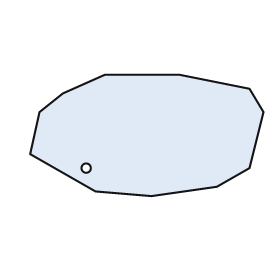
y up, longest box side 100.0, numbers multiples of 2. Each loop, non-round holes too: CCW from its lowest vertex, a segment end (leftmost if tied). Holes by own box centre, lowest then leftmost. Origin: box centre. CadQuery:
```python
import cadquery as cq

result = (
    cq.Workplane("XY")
    .moveTo(2.0, -26.0)
    .lineTo(30.0, -22.0)
    .lineTo(44.0, -14.0)
    .lineTo(50.0, 10.0)
    .lineTo(44.0, 20.0)
    .lineTo(14.0, 26.0)
    .lineTo(-18.0, 26.0)
    .lineTo(-36.0, 18.0)
    .lineTo(-46.0, 10.0)
    .lineTo(-50.0, -8.0)
    .lineTo(-22.0, -24.0)
    .close()
    .moveTo(-26.0, -14.0)
    .circle(2.0)
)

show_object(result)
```